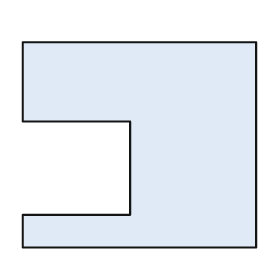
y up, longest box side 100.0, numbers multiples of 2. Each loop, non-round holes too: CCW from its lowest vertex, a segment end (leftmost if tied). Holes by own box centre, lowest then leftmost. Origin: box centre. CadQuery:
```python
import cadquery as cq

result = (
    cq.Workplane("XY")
    .moveTo(-50.0, -44.0)
    .lineTo(50.0, -44.0)
    .lineTo(50.0, 44.0)
    .lineTo(-50.0, 44.0)
    .lineTo(-50.0, 10.0)
    .lineTo(-4.0, 10.0)
    .lineTo(-4.0, -30.0)
    .lineTo(-50.0, -30.0)
    .close()
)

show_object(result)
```